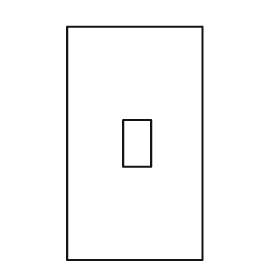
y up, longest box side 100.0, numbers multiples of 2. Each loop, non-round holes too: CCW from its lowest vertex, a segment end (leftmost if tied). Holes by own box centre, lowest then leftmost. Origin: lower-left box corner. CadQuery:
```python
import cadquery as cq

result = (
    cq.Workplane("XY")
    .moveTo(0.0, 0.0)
    .lineTo(58.0, 0.0)
    .lineTo(58.0, 100.0)
    .lineTo(0.0, 100.0)
    .close()
    .moveTo(24.0, 40.0)
    .lineTo(36.0, 40.0)
    .lineTo(36.0, 60.0)
    .lineTo(24.0, 60.0)
    .close()
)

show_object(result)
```